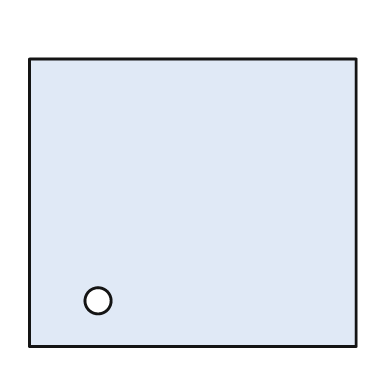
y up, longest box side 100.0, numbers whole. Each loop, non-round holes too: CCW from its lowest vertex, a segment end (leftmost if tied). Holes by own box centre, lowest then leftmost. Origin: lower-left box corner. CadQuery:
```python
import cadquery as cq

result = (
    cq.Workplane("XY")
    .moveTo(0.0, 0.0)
    .lineTo(100.0, 0.0)
    .lineTo(100.0, 88.0)
    .lineTo(0.0, 88.0)
    .close()
    .moveTo(21.0, 14.0)
    .circle(4.0)
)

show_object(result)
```